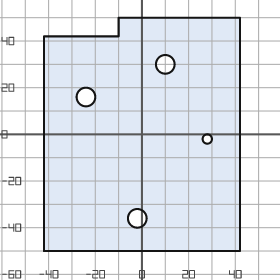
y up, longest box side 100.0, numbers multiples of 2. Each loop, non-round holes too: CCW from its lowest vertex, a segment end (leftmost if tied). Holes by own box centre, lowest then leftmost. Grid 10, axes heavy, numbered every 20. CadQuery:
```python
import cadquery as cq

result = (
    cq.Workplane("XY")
    .moveTo(-42.0, -50.0)
    .lineTo(42.0, -50.0)
    .lineTo(42.0, 50.0)
    .lineTo(-10.0, 50.0)
    .lineTo(-10.0, 42.0)
    .lineTo(-42.0, 42.0)
    .close()
    .moveTo(-2.0, -36.0)
    .circle(4.0)
    .moveTo(28.0, -2.0)
    .circle(2.0)
    .moveTo(-24.0, 16.0)
    .circle(4.0)
    .moveTo(10.0, 30.0)
    .circle(4.0)
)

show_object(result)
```